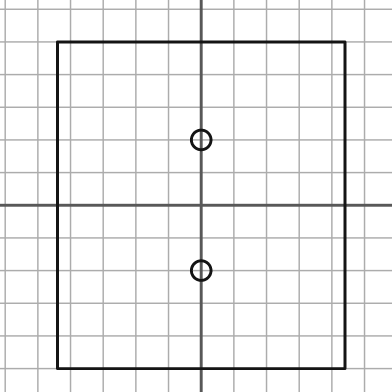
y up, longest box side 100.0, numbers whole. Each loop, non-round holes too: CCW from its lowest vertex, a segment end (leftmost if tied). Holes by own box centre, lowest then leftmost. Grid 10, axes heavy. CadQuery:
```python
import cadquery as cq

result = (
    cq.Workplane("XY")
    .moveTo(-44.0, -50.0)
    .lineTo(44.0, -50.0)
    .lineTo(44.0, 50.0)
    .lineTo(-44.0, 50.0)
    .close()
    .moveTo(0.0, -20.0)
    .circle(3.0)
    .moveTo(0.0, 20.0)
    .circle(3.0)
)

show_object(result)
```